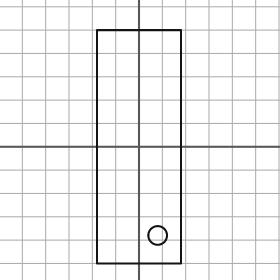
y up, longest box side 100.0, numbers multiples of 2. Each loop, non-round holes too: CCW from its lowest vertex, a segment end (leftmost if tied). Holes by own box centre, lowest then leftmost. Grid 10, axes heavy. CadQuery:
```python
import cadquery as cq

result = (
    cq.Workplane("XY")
    .moveTo(-18.0, -50.0)
    .lineTo(18.0, -50.0)
    .lineTo(18.0, 50.0)
    .lineTo(-18.0, 50.0)
    .close()
    .moveTo(8.0, -38.0)
    .circle(4.0)
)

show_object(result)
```